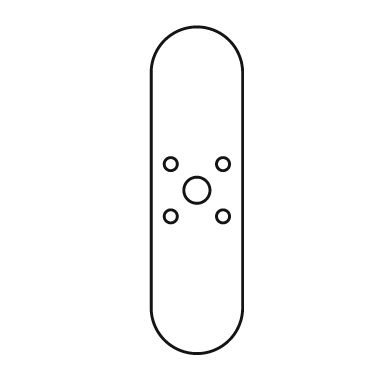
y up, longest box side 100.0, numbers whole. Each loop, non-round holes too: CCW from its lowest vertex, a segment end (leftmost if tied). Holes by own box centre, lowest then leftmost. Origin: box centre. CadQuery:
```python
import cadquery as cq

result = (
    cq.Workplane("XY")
    .moveTo(-14.0, -36.0)
    .threePointArc((0.0, -50.0), (14.0, -36.0))
    .lineTo(14.0, 36.0)
    .threePointArc((0.0, 50.0), (-14.0, 36.0))
    .close()
    .moveTo(-8.0, -8.0)
    .circle(2.0)
    .moveTo(8.0, -8.0)
    .circle(2.0)
    .moveTo(0.0, 0.0)
    .circle(4.0)
    .moveTo(-8.0, 8.0)
    .circle(2.0)
    .moveTo(8.0, 8.0)
    .circle(2.0)
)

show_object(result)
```